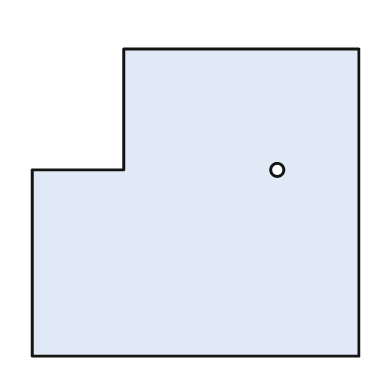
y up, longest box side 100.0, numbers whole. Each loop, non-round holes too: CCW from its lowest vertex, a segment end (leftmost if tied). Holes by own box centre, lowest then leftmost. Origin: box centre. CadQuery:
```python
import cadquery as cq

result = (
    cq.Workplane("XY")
    .moveTo(-50.0, -47.0)
    .lineTo(50.0, -47.0)
    .lineTo(50.0, 47.0)
    .lineTo(-22.0, 47.0)
    .lineTo(-22.0, 10.0)
    .lineTo(-50.0, 10.0)
    .close()
    .moveTo(25.0, 10.0)
    .circle(2.0)
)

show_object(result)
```